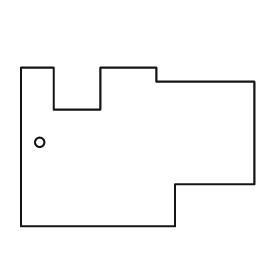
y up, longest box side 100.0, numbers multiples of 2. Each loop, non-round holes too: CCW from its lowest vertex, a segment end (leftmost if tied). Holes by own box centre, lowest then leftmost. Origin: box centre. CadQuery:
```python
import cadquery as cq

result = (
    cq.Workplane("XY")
    .moveTo(-50.0, -34.0)
    .lineTo(16.0, -34.0)
    .lineTo(16.0, -16.0)
    .lineTo(50.0, -16.0)
    .lineTo(50.0, 28.0)
    .lineTo(8.0, 28.0)
    .lineTo(8.0, 34.0)
    .lineTo(-16.0, 34.0)
    .lineTo(-16.0, 16.0)
    .lineTo(-36.0, 16.0)
    .lineTo(-36.0, 34.0)
    .lineTo(-50.0, 34.0)
    .close()
    .moveTo(-42.0, 2.0)
    .circle(2.0)
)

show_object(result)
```